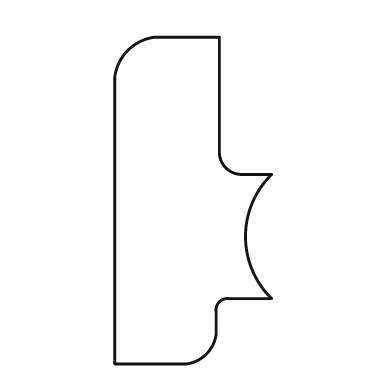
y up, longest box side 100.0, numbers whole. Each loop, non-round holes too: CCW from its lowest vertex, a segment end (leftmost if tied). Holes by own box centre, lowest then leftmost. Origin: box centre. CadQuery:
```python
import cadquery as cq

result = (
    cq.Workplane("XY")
    .moveTo(-24.0, -50.0)
    .lineTo(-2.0, -50.0)
    .threePointArc((4.0, -47.0), (7.0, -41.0))
    .lineTo(7.0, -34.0)
    .threePointArc((8.0, -31.0), (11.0, -30.0))
    .lineTo(24.0, -30.0)
    .threePointArc((16.0, -11.0), (24.0, 8.0))
    .lineTo(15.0, 8.0)
    .threePointArc((10.0, 10.0), (8.0, 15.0))
    .lineTo(8.0, 50.0)
    .lineTo(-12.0, 50.0)
    .threePointArc((-20.0, 46.0), (-24.0, 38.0))
    .close()
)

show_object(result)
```